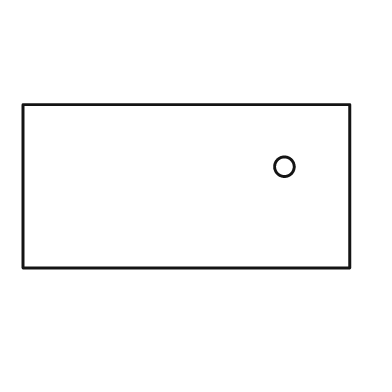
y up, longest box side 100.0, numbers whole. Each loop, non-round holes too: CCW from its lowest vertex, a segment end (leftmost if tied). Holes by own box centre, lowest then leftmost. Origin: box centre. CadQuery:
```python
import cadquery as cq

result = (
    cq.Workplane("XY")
    .moveTo(-50.0, -25.0)
    .lineTo(50.0, -25.0)
    .lineTo(50.0, 25.0)
    .lineTo(-50.0, 25.0)
    .close()
    .moveTo(30.0, 6.0)
    .circle(3.0)
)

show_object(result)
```